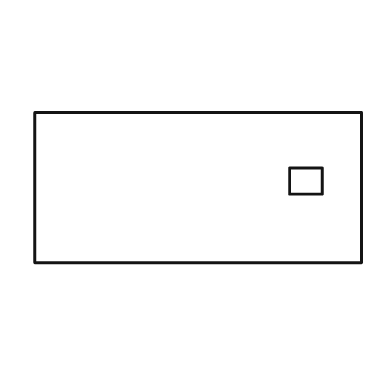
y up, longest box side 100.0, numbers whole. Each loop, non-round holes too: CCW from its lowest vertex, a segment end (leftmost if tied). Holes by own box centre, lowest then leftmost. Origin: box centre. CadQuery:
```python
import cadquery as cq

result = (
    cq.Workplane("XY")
    .moveTo(-50.0, -23.0)
    .lineTo(50.0, -23.0)
    .lineTo(50.0, 23.0)
    .lineTo(-50.0, 23.0)
    .close()
    .moveTo(28.0, -2.0)
    .lineTo(38.0, -2.0)
    .lineTo(38.0, 6.0)
    .lineTo(28.0, 6.0)
    .close()
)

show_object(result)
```